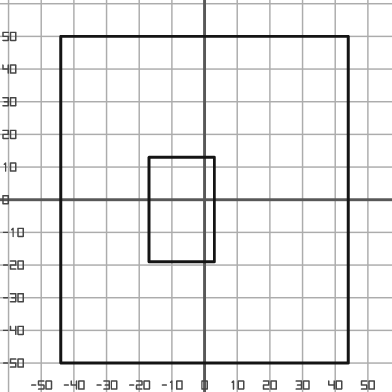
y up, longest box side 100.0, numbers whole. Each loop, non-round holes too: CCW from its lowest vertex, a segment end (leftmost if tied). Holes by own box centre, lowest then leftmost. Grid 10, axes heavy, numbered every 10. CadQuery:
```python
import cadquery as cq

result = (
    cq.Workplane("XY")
    .moveTo(-44.0, -50.0)
    .lineTo(44.0, -50.0)
    .lineTo(44.0, 50.0)
    .lineTo(-44.0, 50.0)
    .close()
    .moveTo(-17.0, -19.0)
    .lineTo(3.0, -19.0)
    .lineTo(3.0, 13.0)
    .lineTo(-17.0, 13.0)
    .close()
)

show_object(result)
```